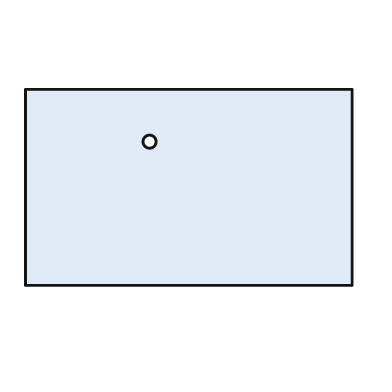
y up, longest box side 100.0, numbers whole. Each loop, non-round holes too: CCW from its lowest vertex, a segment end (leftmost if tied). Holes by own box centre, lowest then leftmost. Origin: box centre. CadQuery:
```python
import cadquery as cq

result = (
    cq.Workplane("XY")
    .moveTo(-50.0, -30.0)
    .lineTo(50.0, -30.0)
    .lineTo(50.0, 30.0)
    .lineTo(-50.0, 30.0)
    .close()
    .moveTo(-12.0, 14.0)
    .circle(2.0)
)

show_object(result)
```